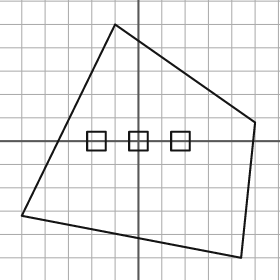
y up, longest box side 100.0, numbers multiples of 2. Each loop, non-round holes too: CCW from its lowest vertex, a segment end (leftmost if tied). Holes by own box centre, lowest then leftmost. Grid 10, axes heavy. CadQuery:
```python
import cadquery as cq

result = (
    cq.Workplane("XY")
    .moveTo(44.0, -50.0)
    .lineTo(50.0, 8.0)
    .lineTo(-10.0, 50.0)
    .lineTo(-50.0, -32.0)
    .close()
    .moveTo(-22.0, -4.0)
    .lineTo(-14.0, -4.0)
    .lineTo(-14.0, 4.0)
    .lineTo(-22.0, 4.0)
    .close()
    .moveTo(-4.0, -4.0)
    .lineTo(4.0, -4.0)
    .lineTo(4.0, 4.0)
    .lineTo(-4.0, 4.0)
    .close()
    .moveTo(14.0, -4.0)
    .lineTo(22.0, -4.0)
    .lineTo(22.0, 4.0)
    .lineTo(14.0, 4.0)
    .close()
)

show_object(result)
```